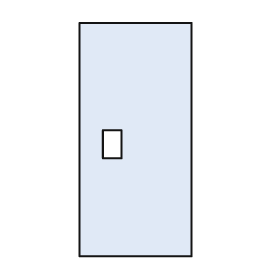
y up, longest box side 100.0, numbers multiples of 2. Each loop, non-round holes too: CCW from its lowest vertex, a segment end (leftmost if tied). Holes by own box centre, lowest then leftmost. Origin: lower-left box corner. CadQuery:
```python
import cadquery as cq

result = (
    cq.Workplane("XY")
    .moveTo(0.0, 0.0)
    .lineTo(48.0, 0.0)
    .lineTo(48.0, 100.0)
    .lineTo(0.0, 100.0)
    .close()
    .moveTo(10.0, 42.0)
    .lineTo(18.0, 42.0)
    .lineTo(18.0, 54.0)
    .lineTo(10.0, 54.0)
    .close()
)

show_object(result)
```